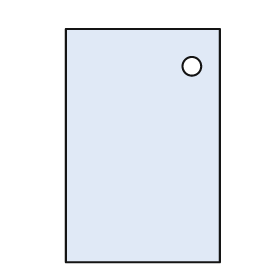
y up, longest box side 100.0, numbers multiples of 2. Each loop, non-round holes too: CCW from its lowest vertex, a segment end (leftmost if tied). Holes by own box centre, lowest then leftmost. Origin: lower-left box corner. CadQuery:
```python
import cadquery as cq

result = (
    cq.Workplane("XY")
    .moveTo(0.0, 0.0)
    .lineTo(66.0, 0.0)
    .lineTo(66.0, 100.0)
    .lineTo(0.0, 100.0)
    .close()
    .moveTo(54.0, 84.0)
    .circle(4.0)
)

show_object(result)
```